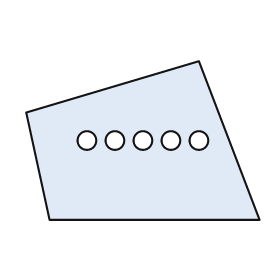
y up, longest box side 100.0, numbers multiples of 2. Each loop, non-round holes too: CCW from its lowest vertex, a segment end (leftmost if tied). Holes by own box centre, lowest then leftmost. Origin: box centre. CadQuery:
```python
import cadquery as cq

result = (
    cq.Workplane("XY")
    .moveTo(-40.0, -34.0)
    .lineTo(50.0, -34.0)
    .lineTo(24.0, 34.0)
    .lineTo(-50.0, 12.0)
    .close()
    .moveTo(-24.0, 0.0)
    .circle(4.0)
    .moveTo(-12.0, 0.0)
    .circle(4.0)
    .moveTo(0.0, 0.0)
    .circle(4.0)
    .moveTo(12.0, 0.0)
    .circle(4.0)
    .moveTo(24.0, 0.0)
    .circle(4.0)
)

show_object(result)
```